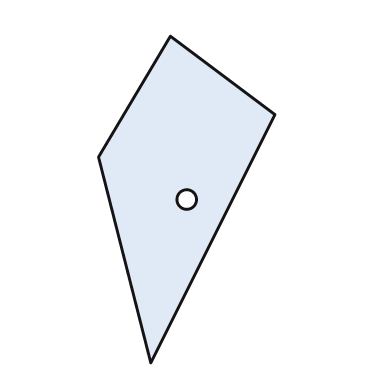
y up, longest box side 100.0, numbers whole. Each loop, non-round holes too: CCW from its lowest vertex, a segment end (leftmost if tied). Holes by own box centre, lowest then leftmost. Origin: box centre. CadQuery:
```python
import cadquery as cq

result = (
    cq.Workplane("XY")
    .moveTo(-11.0, -50.0)
    .lineTo(27.0, 26.0)
    .lineTo(-5.0, 50.0)
    .lineTo(-27.0, 13.0)
    .close()
    .moveTo(0.0, 0.0)
    .circle(3.0)
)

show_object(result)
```